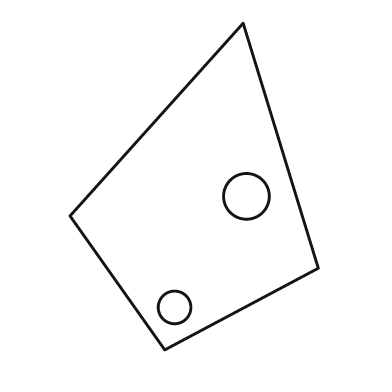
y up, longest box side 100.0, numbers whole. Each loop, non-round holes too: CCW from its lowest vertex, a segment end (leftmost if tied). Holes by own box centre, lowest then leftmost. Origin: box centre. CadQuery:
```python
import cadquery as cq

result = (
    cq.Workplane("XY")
    .moveTo(-9.0, -50.0)
    .lineTo(38.0, -25.0)
    .lineTo(15.0, 50.0)
    .lineTo(-38.0, -9.0)
    .close()
    .moveTo(-6.0, -37.0)
    .circle(5.0)
    .moveTo(16.0, -3.0)
    .circle(7.0)
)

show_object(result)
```